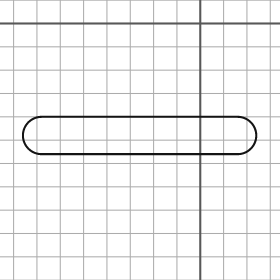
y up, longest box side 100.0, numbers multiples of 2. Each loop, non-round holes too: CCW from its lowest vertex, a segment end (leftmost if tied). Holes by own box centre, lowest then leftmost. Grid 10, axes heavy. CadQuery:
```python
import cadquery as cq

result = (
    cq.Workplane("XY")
    .moveTo(-68.0, -56.0)
    .lineTo(16.0, -56.0)
    .threePointArc((24.0, -48.0), (16.0, -40.0))
    .lineTo(-68.0, -40.0)
    .threePointArc((-76.0, -48.0), (-68.0, -56.0))
    .close()
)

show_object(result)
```